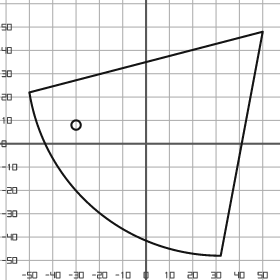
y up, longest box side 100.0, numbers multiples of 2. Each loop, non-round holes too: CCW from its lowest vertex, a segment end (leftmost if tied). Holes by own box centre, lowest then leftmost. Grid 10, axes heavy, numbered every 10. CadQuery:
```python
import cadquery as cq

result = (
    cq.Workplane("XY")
    .moveTo(32.0, -48.0)
    .lineTo(50.0, 48.0)
    .lineTo(-50.0, 22.0)
    .threePointArc((-22.0, -28.0), (32.0, -48.0))
    .close()
    .moveTo(-30.0, 8.0)
    .circle(2.0)
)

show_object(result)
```